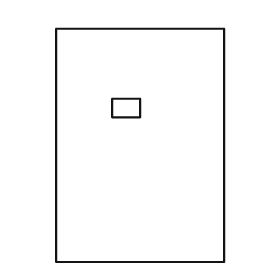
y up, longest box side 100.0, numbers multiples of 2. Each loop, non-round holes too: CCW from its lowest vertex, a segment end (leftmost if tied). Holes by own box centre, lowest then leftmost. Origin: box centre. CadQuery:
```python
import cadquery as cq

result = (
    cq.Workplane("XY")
    .moveTo(-36.0, -50.0)
    .lineTo(36.0, -50.0)
    .lineTo(36.0, 50.0)
    .lineTo(-36.0, 50.0)
    .close()
    .moveTo(-12.0, 12.0)
    .lineTo(0.0, 12.0)
    .lineTo(0.0, 20.0)
    .lineTo(-12.0, 20.0)
    .close()
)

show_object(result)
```